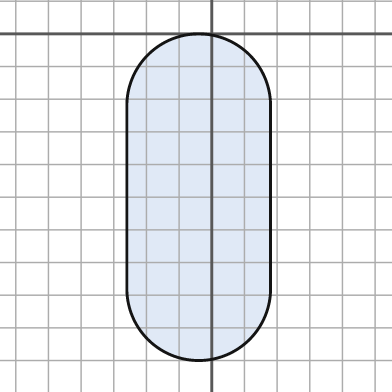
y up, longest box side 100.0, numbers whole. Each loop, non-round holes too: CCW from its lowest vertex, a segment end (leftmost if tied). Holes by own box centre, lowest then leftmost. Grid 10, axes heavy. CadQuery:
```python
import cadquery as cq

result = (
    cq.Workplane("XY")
    .moveTo(-26.0, -78.0)
    .threePointArc((-4.0, -100.0), (18.0, -78.0))
    .lineTo(18.0, -22.0)
    .threePointArc((-4.0, 0.0), (-26.0, -22.0))
    .close()
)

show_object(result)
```